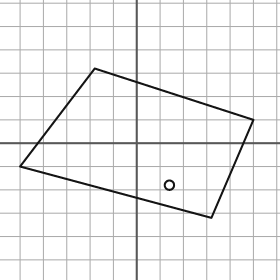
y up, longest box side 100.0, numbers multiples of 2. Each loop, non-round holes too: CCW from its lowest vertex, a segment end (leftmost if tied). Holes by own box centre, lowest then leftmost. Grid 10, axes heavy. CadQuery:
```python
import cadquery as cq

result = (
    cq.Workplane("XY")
    .moveTo(32.0, -32.0)
    .lineTo(50.0, 10.0)
    .lineTo(-18.0, 32.0)
    .lineTo(-50.0, -10.0)
    .close()
    .moveTo(14.0, -18.0)
    .circle(2.0)
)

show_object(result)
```